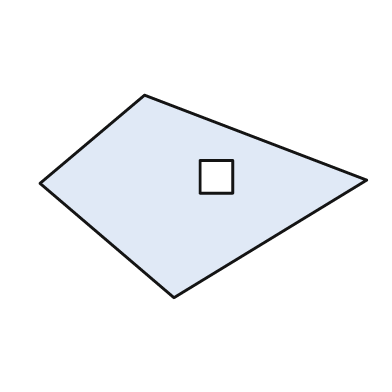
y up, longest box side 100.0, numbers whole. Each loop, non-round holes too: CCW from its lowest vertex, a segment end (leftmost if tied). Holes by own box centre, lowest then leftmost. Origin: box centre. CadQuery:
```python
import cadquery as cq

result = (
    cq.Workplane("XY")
    .moveTo(-9.0, -31.0)
    .lineTo(50.0, 5.0)
    .lineTo(-18.0, 31.0)
    .lineTo(-50.0, 4.0)
    .close()
    .moveTo(-1.0, 1.0)
    .lineTo(9.0, 1.0)
    .lineTo(9.0, 11.0)
    .lineTo(-1.0, 11.0)
    .close()
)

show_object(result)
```